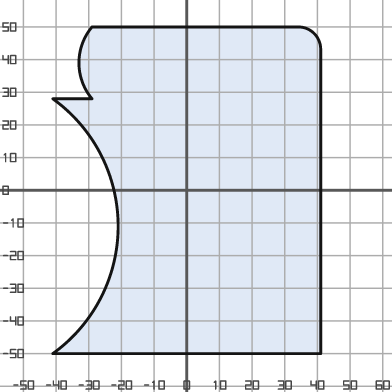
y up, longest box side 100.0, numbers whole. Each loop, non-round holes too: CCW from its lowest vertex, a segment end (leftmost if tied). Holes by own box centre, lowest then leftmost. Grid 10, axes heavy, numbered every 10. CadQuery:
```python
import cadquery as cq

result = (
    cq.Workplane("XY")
    .moveTo(-41.0, -50.0)
    .lineTo(41.0, -50.0)
    .lineTo(41.0, 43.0)
    .threePointArc((39.0, 48.0), (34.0, 50.0))
    .lineTo(-29.0, 50.0)
    .threePointArc((-33.0, 39.0), (-29.0, 28.0))
    .lineTo(-41.0, 28.0)
    .threePointArc((-21.0, -11.0), (-41.0, -50.0))
    .close()
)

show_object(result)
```